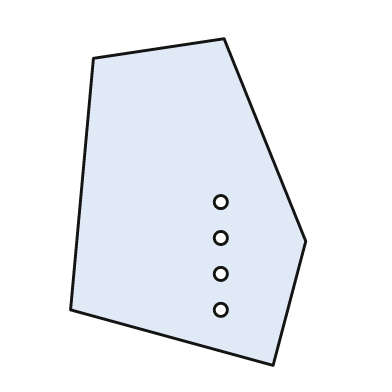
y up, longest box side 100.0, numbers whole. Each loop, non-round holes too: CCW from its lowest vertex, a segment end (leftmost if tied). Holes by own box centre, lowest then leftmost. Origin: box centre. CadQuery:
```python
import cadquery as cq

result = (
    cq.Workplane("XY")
    .moveTo(26.0, -50.0)
    .lineTo(36.0, -12.0)
    .lineTo(11.0, 50.0)
    .lineTo(-29.0, 44.0)
    .lineTo(-36.0, -33.0)
    .close()
    .moveTo(10.0, -33.0)
    .circle(2.0)
    .moveTo(10.0, -22.0)
    .circle(2.0)
    .moveTo(10.0, -11.0)
    .circle(2.0)
    .moveTo(10.0, 0.0)
    .circle(2.0)
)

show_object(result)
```